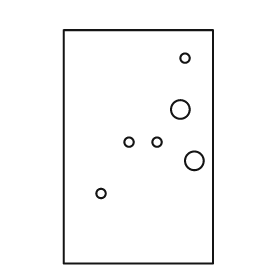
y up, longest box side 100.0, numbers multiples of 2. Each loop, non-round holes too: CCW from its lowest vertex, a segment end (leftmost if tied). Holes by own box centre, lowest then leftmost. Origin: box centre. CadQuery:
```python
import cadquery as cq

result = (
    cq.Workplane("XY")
    .moveTo(-32.0, -50.0)
    .lineTo(32.0, -50.0)
    .lineTo(32.0, 50.0)
    .lineTo(-32.0, 50.0)
    .close()
    .moveTo(-16.0, -20.0)
    .circle(2.0)
    .moveTo(24.0, -6.0)
    .circle(4.0)
    .moveTo(-4.0, 2.0)
    .circle(2.0)
    .moveTo(8.0, 2.0)
    .circle(2.0)
    .moveTo(18.0, 16.0)
    .circle(4.0)
    .moveTo(20.0, 38.0)
    .circle(2.0)
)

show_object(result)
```